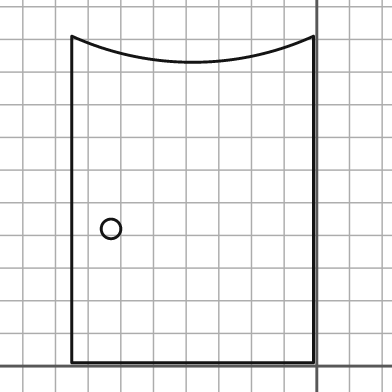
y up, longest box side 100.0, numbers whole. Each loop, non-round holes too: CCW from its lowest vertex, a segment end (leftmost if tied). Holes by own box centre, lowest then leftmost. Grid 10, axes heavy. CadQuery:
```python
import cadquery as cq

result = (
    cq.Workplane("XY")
    .moveTo(-75.0, 1.0)
    .lineTo(-1.0, 1.0)
    .lineTo(-1.0, 101.0)
    .threePointArc((-38.0, 93.0), (-75.0, 101.0))
    .close()
    .moveTo(-63.0, 42.0)
    .circle(3.0)
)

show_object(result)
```